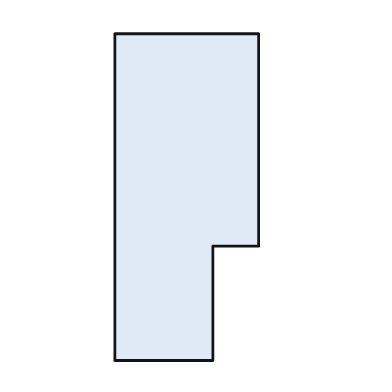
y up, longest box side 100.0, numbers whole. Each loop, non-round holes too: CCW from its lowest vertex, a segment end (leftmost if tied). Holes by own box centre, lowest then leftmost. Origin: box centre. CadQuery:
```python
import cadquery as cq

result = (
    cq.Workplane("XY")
    .moveTo(-22.0, -50.0)
    .lineTo(8.0, -50.0)
    .lineTo(8.0, -15.0)
    .lineTo(22.0, -15.0)
    .lineTo(22.0, 50.0)
    .lineTo(-22.0, 50.0)
    .close()
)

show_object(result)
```